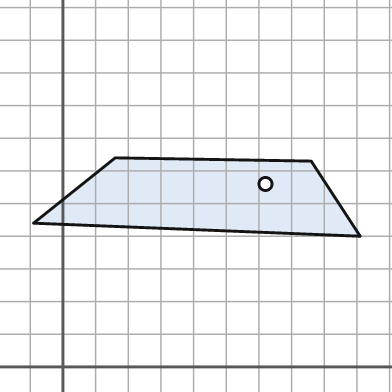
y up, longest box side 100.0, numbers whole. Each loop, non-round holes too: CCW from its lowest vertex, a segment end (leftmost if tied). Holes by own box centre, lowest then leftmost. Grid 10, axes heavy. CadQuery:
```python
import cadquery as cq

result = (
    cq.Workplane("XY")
    .moveTo(91.0, 40.0)
    .lineTo(76.0, 63.0)
    .lineTo(16.0, 64.0)
    .lineTo(-9.0, 44.0)
    .close()
    .moveTo(62.0, 56.0)
    .circle(2.0)
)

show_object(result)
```